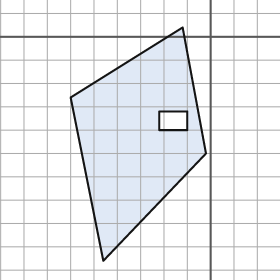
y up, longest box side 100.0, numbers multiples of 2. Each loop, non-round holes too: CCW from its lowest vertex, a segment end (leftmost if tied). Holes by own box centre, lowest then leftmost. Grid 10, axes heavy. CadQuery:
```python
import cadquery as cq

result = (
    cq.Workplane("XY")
    .moveTo(-46.0, -96.0)
    .lineTo(-2.0, -50.0)
    .lineTo(-12.0, 4.0)
    .lineTo(-60.0, -26.0)
    .close()
    .moveTo(-22.0, -40.0)
    .lineTo(-10.0, -40.0)
    .lineTo(-10.0, -32.0)
    .lineTo(-22.0, -32.0)
    .close()
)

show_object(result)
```